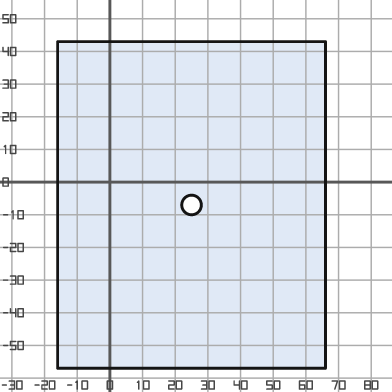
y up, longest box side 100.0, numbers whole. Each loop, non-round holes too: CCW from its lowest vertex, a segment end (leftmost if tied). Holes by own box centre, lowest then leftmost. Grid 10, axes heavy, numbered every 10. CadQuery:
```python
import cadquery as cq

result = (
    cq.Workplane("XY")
    .moveTo(-16.0, -57.0)
    .lineTo(66.0, -57.0)
    .lineTo(66.0, 43.0)
    .lineTo(-16.0, 43.0)
    .close()
    .moveTo(25.0, -7.0)
    .circle(3.0)
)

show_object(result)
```